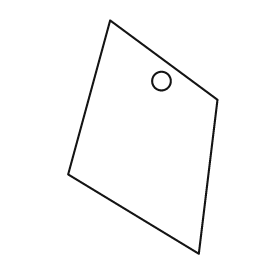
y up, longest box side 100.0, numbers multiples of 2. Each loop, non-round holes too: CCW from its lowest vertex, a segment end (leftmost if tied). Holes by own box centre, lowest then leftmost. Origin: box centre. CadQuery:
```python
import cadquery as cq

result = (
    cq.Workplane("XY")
    .moveTo(24.0, -50.0)
    .lineTo(32.0, 16.0)
    .lineTo(-14.0, 50.0)
    .lineTo(-32.0, -16.0)
    .close()
    .moveTo(8.0, 24.0)
    .circle(4.0)
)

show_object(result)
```